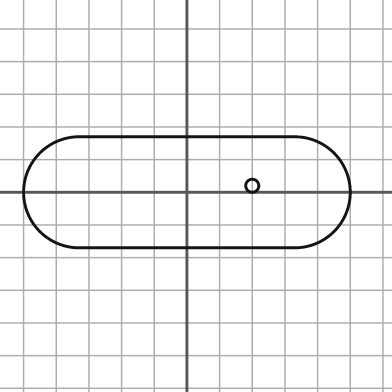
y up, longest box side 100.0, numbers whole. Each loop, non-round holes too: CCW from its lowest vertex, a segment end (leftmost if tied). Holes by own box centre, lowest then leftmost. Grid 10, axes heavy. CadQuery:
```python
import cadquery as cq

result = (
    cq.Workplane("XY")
    .moveTo(-33.0, -17.0)
    .lineTo(33.0, -17.0)
    .threePointArc((50.0, 0.0), (33.0, 17.0))
    .lineTo(-33.0, 17.0)
    .threePointArc((-50.0, 0.0), (-33.0, -17.0))
    .close()
    .moveTo(20.0, 2.0)
    .circle(2.0)
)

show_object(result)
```